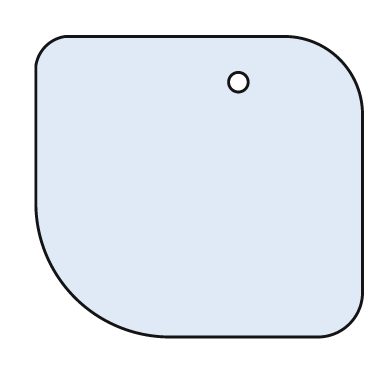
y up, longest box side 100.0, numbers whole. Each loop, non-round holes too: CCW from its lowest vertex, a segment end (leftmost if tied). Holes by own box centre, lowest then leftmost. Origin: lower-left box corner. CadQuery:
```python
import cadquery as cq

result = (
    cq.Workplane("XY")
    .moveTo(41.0, 0.0)
    .lineTo(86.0, 0.0)
    .threePointArc((96.0, 4.0), (100.0, 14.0))
    .lineTo(100.0, 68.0)
    .threePointArc((93.0, 85.0), (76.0, 92.0))
    .lineTo(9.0, 92.0)
    .threePointArc((3.0, 89.0), (0.0, 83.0))
    .lineTo(0.0, 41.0)
    .threePointArc((12.0, 12.0), (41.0, 0.0))
    .close()
    .moveTo(62.0, 78.0)
    .circle(3.0)
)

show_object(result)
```